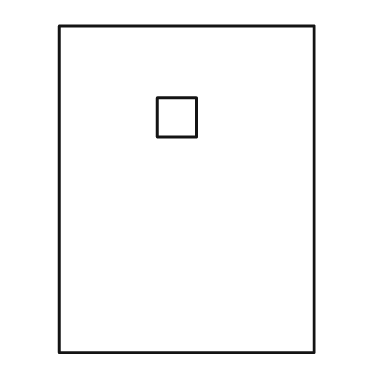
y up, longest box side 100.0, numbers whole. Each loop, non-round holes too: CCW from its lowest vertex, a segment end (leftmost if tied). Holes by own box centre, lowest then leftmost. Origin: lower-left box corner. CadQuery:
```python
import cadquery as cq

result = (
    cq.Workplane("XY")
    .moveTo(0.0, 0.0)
    .lineTo(78.0, 0.0)
    .lineTo(78.0, 100.0)
    .lineTo(0.0, 100.0)
    .close()
    .moveTo(30.0, 66.0)
    .lineTo(42.0, 66.0)
    .lineTo(42.0, 78.0)
    .lineTo(30.0, 78.0)
    .close()
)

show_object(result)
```